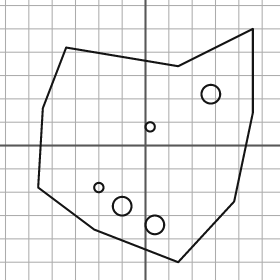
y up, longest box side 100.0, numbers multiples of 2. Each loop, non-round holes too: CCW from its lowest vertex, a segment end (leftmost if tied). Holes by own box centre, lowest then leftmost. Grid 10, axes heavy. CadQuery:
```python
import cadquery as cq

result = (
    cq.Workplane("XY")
    .moveTo(14.0, -50.0)
    .lineTo(38.0, -24.0)
    .lineTo(46.0, 14.0)
    .lineTo(46.0, 50.0)
    .lineTo(14.0, 34.0)
    .lineTo(-34.0, 42.0)
    .lineTo(-44.0, 16.0)
    .lineTo(-46.0, -18.0)
    .lineTo(-22.0, -36.0)
    .close()
    .moveTo(4.0, -34.0)
    .circle(4.0)
    .moveTo(-10.0, -26.0)
    .circle(4.0)
    .moveTo(-20.0, -18.0)
    .circle(2.0)
    .moveTo(2.0, 8.0)
    .circle(2.0)
    .moveTo(28.0, 22.0)
    .circle(4.0)
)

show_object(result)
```